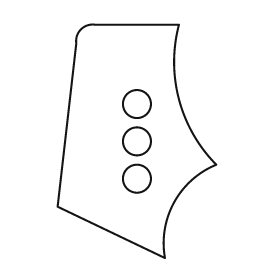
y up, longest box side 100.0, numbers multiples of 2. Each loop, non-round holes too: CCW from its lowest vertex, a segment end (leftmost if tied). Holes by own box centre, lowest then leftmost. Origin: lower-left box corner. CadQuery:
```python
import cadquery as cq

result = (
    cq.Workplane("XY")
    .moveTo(46.0, 0.0)
    .threePointArc((50.0, 24.0), (68.0, 40.0))
    .threePointArc((52.0, 68.0), (52.0, 100.0))
    .lineTo(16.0, 100.0)
    .threePointArc((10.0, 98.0), (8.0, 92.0))
    .lineTo(0.0, 22.0)
    .close()
    .moveTo(34.0, 34.0)
    .circle(6.0)
    .moveTo(34.0, 50.0)
    .circle(6.0)
    .moveTo(34.0, 66.0)
    .circle(6.0)
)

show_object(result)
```